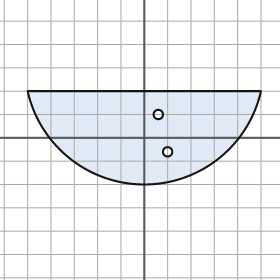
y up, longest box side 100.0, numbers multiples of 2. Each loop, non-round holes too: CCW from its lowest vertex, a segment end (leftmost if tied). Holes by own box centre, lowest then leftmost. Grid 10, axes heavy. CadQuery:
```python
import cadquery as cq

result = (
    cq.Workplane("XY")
    .moveTo(-50.0, 20.0)
    .threePointArc((0.0, -20.0), (50.0, 20.0))
    .close()
    .moveTo(10.0, -6.0)
    .circle(2.0)
    .moveTo(6.0, 10.0)
    .circle(2.0)
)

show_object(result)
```